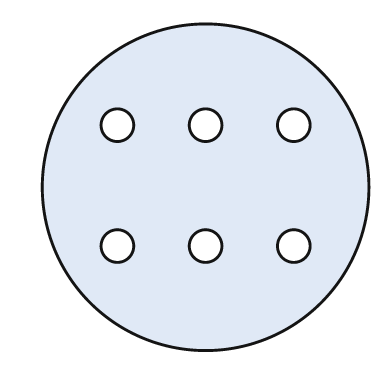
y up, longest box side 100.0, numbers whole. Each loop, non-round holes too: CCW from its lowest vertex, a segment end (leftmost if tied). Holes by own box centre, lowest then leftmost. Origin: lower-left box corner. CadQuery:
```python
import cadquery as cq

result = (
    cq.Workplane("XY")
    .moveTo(50.0, 50.0)
    .circle(50.0)
    .moveTo(23.0, 32.0)
    .circle(5.0)
    .moveTo(50.0, 32.0)
    .circle(5.0)
    .moveTo(77.0, 32.0)
    .circle(5.0)
    .moveTo(23.0, 69.0)
    .circle(5.0)
    .moveTo(50.0, 69.0)
    .circle(5.0)
    .moveTo(77.0, 69.0)
    .circle(5.0)
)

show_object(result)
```